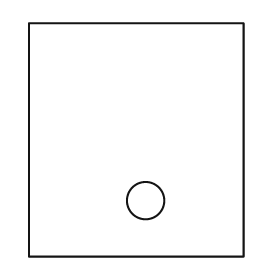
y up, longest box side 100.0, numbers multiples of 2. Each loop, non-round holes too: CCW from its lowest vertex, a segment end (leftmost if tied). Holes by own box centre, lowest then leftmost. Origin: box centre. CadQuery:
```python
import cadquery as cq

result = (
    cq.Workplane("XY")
    .moveTo(-46.0, -50.0)
    .lineTo(46.0, -50.0)
    .lineTo(46.0, 50.0)
    .lineTo(-46.0, 50.0)
    .close()
    .moveTo(4.0, -26.0)
    .circle(8.0)
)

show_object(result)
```